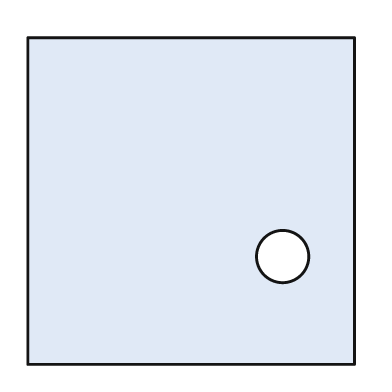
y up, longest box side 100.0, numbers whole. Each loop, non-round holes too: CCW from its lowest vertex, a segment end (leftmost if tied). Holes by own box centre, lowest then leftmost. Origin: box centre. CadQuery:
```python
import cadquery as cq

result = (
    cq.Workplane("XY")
    .moveTo(-50.0, -50.0)
    .lineTo(50.0, -50.0)
    .lineTo(50.0, 50.0)
    .lineTo(-50.0, 50.0)
    .close()
    .moveTo(28.0, -17.0)
    .circle(8.0)
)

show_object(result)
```